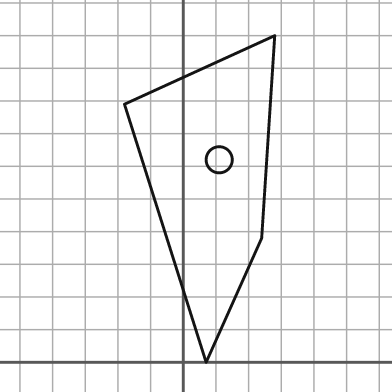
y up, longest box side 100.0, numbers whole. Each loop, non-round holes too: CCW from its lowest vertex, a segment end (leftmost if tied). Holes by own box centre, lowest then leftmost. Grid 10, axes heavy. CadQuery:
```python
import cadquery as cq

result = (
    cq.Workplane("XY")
    .moveTo(7.0, 0.0)
    .lineTo(24.0, 38.0)
    .lineTo(28.0, 100.0)
    .lineTo(-18.0, 79.0)
    .close()
    .moveTo(11.0, 62.0)
    .circle(4.0)
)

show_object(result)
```